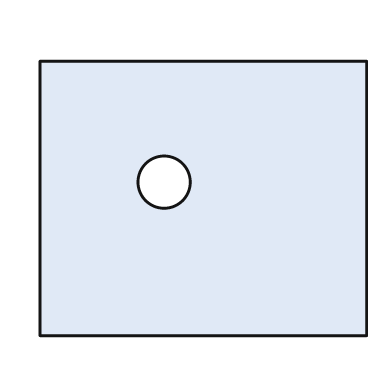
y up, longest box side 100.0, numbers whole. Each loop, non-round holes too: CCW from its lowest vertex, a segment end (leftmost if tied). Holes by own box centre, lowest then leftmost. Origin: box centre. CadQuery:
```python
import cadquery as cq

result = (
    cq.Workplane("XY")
    .moveTo(-50.0, -42.0)
    .lineTo(50.0, -42.0)
    .lineTo(50.0, 42.0)
    .lineTo(-50.0, 42.0)
    .close()
    .moveTo(-12.0, 5.0)
    .circle(8.0)
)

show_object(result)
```